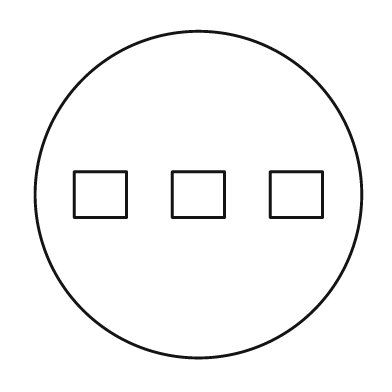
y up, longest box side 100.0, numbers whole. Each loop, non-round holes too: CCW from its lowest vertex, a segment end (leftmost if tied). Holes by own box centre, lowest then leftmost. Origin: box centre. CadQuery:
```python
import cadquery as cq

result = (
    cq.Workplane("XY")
    .moveTo(0.0, 0.0)
    .circle(50.0)
    .moveTo(-38.0, -7.0)
    .lineTo(-22.0, -7.0)
    .lineTo(-22.0, 7.0)
    .lineTo(-38.0, 7.0)
    .close()
    .moveTo(-8.0, -7.0)
    .lineTo(8.0, -7.0)
    .lineTo(8.0, 7.0)
    .lineTo(-8.0, 7.0)
    .close()
    .moveTo(22.0, -7.0)
    .lineTo(38.0, -7.0)
    .lineTo(38.0, 7.0)
    .lineTo(22.0, 7.0)
    .close()
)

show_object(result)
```